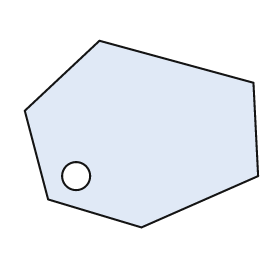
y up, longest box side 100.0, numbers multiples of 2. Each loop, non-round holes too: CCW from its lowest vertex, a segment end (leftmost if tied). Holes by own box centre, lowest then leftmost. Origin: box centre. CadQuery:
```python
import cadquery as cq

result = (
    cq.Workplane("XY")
    .moveTo(0.0, -40.0)
    .lineTo(50.0, -18.0)
    .lineTo(48.0, 22.0)
    .lineTo(-18.0, 40.0)
    .lineTo(-50.0, 10.0)
    .lineTo(-40.0, -28.0)
    .close()
    .moveTo(-28.0, -18.0)
    .circle(6.0)
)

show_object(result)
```